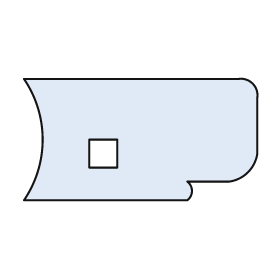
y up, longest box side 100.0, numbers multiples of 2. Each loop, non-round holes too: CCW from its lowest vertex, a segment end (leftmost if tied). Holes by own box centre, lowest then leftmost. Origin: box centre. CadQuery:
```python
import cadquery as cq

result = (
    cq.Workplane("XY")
    .moveTo(-50.0, -26.0)
    .lineTo(20.0, -26.0)
    .threePointArc((22.0, -22.0), (20.0, -18.0))
    .lineTo(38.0, -18.0)
    .threePointArc((46.0, -14.0), (50.0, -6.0))
    .lineTo(50.0, 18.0)
    .threePointArc((48.0, 24.0), (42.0, 26.0))
    .lineTo(-50.0, 26.0)
    .threePointArc((-42.0, 0.0), (-50.0, -26.0))
    .close()
    .moveTo(-22.0, -12.0)
    .lineTo(-10.0, -12.0)
    .lineTo(-10.0, 0.0)
    .lineTo(-22.0, 0.0)
    .close()
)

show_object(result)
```